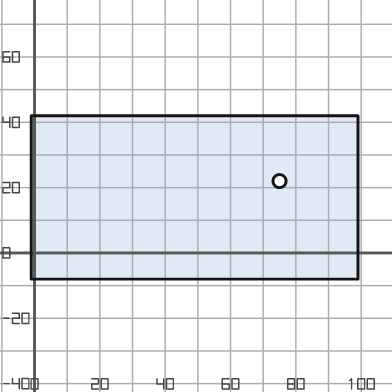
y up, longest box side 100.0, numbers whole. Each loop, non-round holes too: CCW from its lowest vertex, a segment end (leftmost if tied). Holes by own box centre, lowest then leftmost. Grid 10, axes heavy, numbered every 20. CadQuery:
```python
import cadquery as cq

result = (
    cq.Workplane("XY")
    .moveTo(-1.0, -8.0)
    .lineTo(99.0, -8.0)
    .lineTo(99.0, 42.0)
    .lineTo(-1.0, 42.0)
    .close()
    .moveTo(75.0, 22.0)
    .circle(2.0)
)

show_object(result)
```